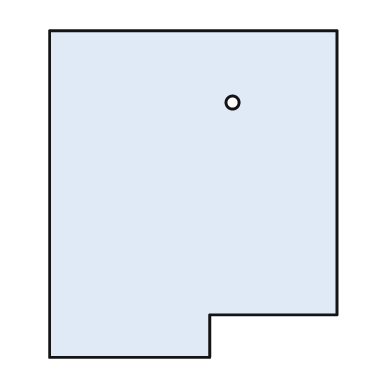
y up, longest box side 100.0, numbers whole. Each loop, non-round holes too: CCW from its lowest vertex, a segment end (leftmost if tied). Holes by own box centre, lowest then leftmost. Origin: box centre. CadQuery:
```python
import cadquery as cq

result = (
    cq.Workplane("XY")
    .moveTo(-44.0, -50.0)
    .lineTo(5.0, -50.0)
    .lineTo(5.0, -37.0)
    .lineTo(44.0, -37.0)
    .lineTo(44.0, 50.0)
    .lineTo(-44.0, 50.0)
    .close()
    .moveTo(12.0, 28.0)
    .circle(2.0)
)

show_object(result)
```